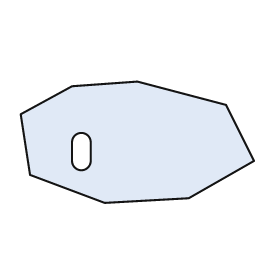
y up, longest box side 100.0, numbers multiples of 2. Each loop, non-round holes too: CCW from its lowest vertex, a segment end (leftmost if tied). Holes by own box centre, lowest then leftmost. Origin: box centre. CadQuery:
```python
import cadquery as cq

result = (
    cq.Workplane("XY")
    .moveTo(-14.0, -26.0)
    .lineTo(22.0, -24.0)
    .lineTo(50.0, -8.0)
    .lineTo(38.0, 16.0)
    .lineTo(0.0, 26.0)
    .lineTo(-28.0, 24.0)
    .lineTo(-50.0, 12.0)
    .lineTo(-46.0, -14.0)
    .close()
    .moveTo(-28.0, -8.0)
    .threePointArc((-24.0, -12.0), (-20.0, -8.0))
    .lineTo(-20.0, 0.0)
    .threePointArc((-24.0, 4.0), (-28.0, 0.0))
    .close()
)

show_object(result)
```